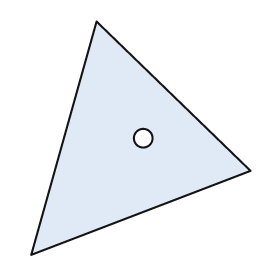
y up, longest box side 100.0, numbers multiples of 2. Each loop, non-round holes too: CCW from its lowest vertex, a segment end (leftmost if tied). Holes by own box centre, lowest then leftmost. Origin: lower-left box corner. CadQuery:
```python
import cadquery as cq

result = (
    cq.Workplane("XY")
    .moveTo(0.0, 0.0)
    .lineTo(94.0, 36.0)
    .lineTo(28.0, 100.0)
    .close()
    .moveTo(48.0, 50.0)
    .circle(4.0)
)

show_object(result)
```